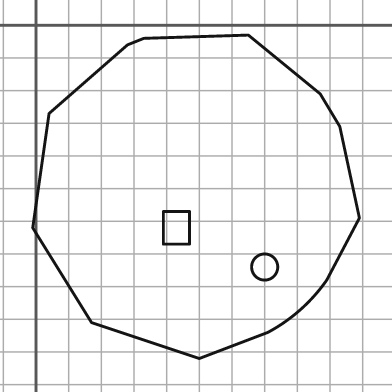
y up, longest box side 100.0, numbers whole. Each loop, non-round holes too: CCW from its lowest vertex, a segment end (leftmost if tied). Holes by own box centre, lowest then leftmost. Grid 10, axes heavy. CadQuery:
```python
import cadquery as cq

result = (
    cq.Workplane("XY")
    .moveTo(50.0, -102.0)
    .lineTo(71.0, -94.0)
    .threePointArc((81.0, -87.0), (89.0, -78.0))
    .lineTo(99.0, -59.0)
    .lineTo(93.0, -31.0)
    .lineTo(87.0, -21.0)
    .lineTo(65.0, -3.0)
    .lineTo(33.0, -4.0)
    .lineTo(28.0, -6.0)
    .lineTo(4.0, -27.0)
    .lineTo(-1.0, -62.0)
    .lineTo(17.0, -91.0)
    .close()
    .moveTo(70.0, -74.0)
    .circle(4.0)
    .moveTo(39.0, -67.0)
    .lineTo(47.0, -67.0)
    .lineTo(47.0, -57.0)
    .lineTo(39.0, -57.0)
    .close()
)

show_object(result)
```